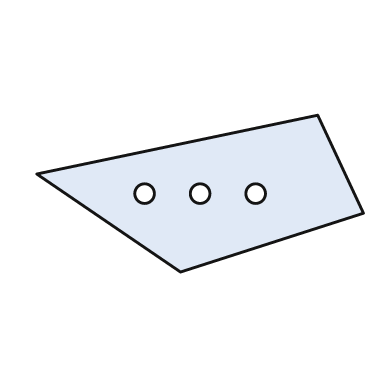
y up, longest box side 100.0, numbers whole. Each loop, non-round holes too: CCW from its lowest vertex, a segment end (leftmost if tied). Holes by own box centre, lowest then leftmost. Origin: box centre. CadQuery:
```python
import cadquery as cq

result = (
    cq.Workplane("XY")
    .moveTo(-6.0, -24.0)
    .lineTo(50.0, -6.0)
    .lineTo(36.0, 24.0)
    .lineTo(-50.0, 6.0)
    .close()
    .moveTo(-17.0, 0.0)
    .circle(3.0)
    .moveTo(0.0, 0.0)
    .circle(3.0)
    .moveTo(17.0, 0.0)
    .circle(3.0)
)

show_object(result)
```